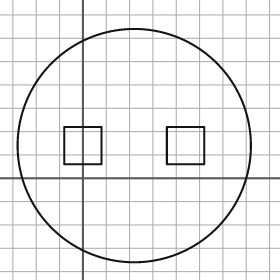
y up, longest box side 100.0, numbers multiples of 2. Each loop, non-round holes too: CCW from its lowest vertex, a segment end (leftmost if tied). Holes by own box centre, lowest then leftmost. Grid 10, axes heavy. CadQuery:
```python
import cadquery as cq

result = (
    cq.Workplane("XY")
    .moveTo(22.0, 14.0)
    .circle(50.0)
    .moveTo(-8.0, 6.0)
    .lineTo(8.0, 6.0)
    .lineTo(8.0, 22.0)
    .lineTo(-8.0, 22.0)
    .close()
    .moveTo(36.0, 6.0)
    .lineTo(52.0, 6.0)
    .lineTo(52.0, 22.0)
    .lineTo(36.0, 22.0)
    .close()
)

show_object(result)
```